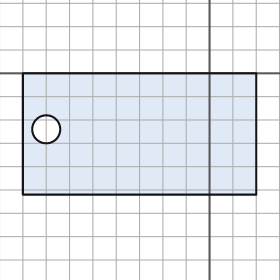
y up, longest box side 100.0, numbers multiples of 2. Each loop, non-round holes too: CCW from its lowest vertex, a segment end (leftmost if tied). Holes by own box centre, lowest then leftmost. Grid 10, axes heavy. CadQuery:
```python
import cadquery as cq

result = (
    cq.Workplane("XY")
    .moveTo(-80.0, -52.0)
    .lineTo(20.0, -52.0)
    .lineTo(20.0, 0.0)
    .lineTo(-80.0, 0.0)
    .close()
    .moveTo(-70.0, -24.0)
    .circle(6.0)
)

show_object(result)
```